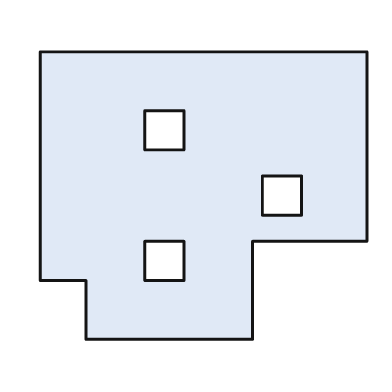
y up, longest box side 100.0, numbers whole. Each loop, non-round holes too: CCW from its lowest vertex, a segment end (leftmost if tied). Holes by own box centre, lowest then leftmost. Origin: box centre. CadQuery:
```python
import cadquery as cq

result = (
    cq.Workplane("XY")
    .moveTo(-36.0, -44.0)
    .lineTo(15.0, -44.0)
    .lineTo(15.0, -14.0)
    .lineTo(50.0, -14.0)
    .lineTo(50.0, 44.0)
    .lineTo(-50.0, 44.0)
    .lineTo(-50.0, -26.0)
    .lineTo(-36.0, -26.0)
    .close()
    .moveTo(-18.0, -26.0)
    .lineTo(-6.0, -26.0)
    .lineTo(-6.0, -14.0)
    .lineTo(-18.0, -14.0)
    .close()
    .moveTo(18.0, -6.0)
    .lineTo(30.0, -6.0)
    .lineTo(30.0, 6.0)
    .lineTo(18.0, 6.0)
    .close()
    .moveTo(-18.0, 14.0)
    .lineTo(-6.0, 14.0)
    .lineTo(-6.0, 26.0)
    .lineTo(-18.0, 26.0)
    .close()
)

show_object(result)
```